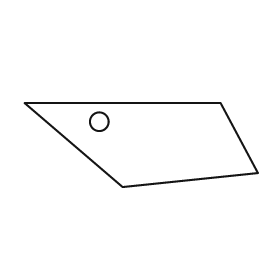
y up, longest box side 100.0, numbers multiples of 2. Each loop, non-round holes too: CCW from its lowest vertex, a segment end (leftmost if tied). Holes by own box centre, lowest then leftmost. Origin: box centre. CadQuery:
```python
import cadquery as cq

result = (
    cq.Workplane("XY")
    .moveTo(-8.0, -18.0)
    .lineTo(50.0, -12.0)
    .lineTo(34.0, 18.0)
    .lineTo(-50.0, 18.0)
    .close()
    .moveTo(-18.0, 10.0)
    .circle(4.0)
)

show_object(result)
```